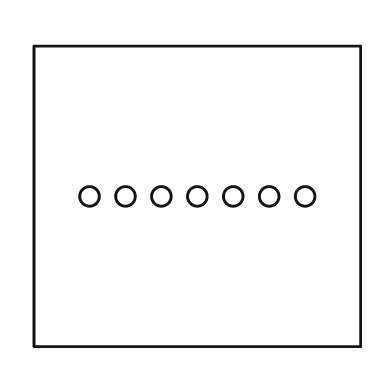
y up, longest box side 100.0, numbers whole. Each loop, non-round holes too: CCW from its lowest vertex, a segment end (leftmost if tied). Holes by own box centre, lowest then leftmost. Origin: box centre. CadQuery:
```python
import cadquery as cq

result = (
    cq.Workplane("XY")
    .moveTo(-50.0, -46.0)
    .lineTo(50.0, -46.0)
    .lineTo(50.0, 46.0)
    .lineTo(-50.0, 46.0)
    .close()
    .moveTo(-33.0, 0.0)
    .circle(3.0)
    .moveTo(-22.0, 0.0)
    .circle(3.0)
    .moveTo(-11.0, 0.0)
    .circle(3.0)
    .moveTo(0.0, 0.0)
    .circle(3.0)
    .moveTo(11.0, 0.0)
    .circle(3.0)
    .moveTo(22.0, 0.0)
    .circle(3.0)
    .moveTo(33.0, 0.0)
    .circle(3.0)
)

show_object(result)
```